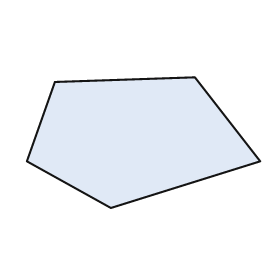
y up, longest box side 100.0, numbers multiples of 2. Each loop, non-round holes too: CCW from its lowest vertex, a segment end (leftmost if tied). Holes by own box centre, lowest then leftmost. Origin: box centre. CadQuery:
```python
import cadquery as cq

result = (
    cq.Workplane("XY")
    .moveTo(-14.0, -28.0)
    .lineTo(50.0, -8.0)
    .lineTo(22.0, 28.0)
    .lineTo(-38.0, 26.0)
    .lineTo(-50.0, -8.0)
    .close()
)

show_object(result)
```